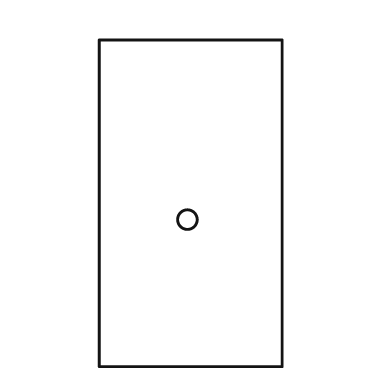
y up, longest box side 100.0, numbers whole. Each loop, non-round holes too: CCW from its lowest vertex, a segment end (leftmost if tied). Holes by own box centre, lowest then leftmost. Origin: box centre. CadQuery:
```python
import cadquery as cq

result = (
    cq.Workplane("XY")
    .moveTo(-28.0, -50.0)
    .lineTo(28.0, -50.0)
    .lineTo(28.0, 50.0)
    .lineTo(-28.0, 50.0)
    .close()
    .moveTo(-1.0, -5.0)
    .circle(3.0)
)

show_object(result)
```